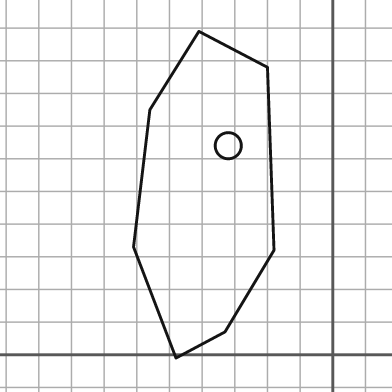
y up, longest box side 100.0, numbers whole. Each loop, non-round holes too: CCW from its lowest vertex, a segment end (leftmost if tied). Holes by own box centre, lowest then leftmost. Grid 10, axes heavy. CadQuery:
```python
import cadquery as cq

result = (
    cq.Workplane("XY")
    .moveTo(-48.0, -1.0)
    .lineTo(-33.0, 7.0)
    .lineTo(-18.0, 32.0)
    .lineTo(-20.0, 88.0)
    .lineTo(-41.0, 99.0)
    .lineTo(-56.0, 75.0)
    .lineTo(-61.0, 33.0)
    .close()
    .moveTo(-32.0, 64.0)
    .circle(4.0)
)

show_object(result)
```